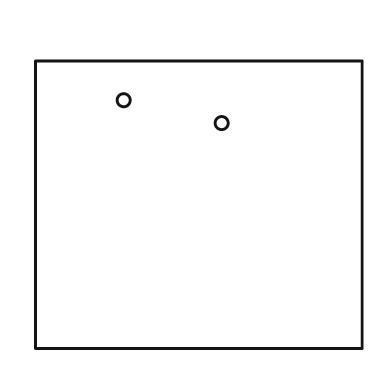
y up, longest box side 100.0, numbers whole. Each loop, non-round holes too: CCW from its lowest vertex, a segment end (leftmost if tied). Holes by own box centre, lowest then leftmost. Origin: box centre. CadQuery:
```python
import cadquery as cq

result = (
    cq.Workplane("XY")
    .moveTo(-50.0, -44.0)
    .lineTo(50.0, -44.0)
    .lineTo(50.0, 44.0)
    .lineTo(-50.0, 44.0)
    .close()
    .moveTo(7.0, 25.0)
    .circle(2.0)
    .moveTo(-23.0, 32.0)
    .circle(2.0)
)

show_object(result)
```